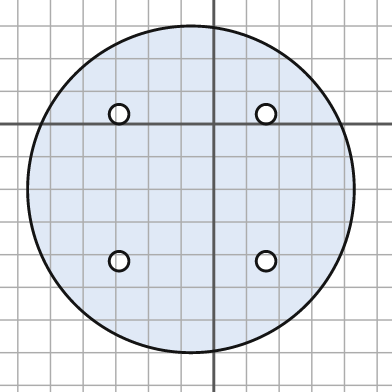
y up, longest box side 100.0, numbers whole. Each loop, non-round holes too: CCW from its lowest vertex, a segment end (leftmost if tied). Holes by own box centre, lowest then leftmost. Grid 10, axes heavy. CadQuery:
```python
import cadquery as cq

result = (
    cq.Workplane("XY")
    .moveTo(-7.0, -20.0)
    .circle(50.0)
    .moveTo(-29.0, -42.0)
    .circle(3.0)
    .moveTo(16.0, -42.0)
    .circle(3.0)
    .moveTo(-29.0, 3.0)
    .circle(3.0)
    .moveTo(16.0, 3.0)
    .circle(3.0)
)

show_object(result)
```